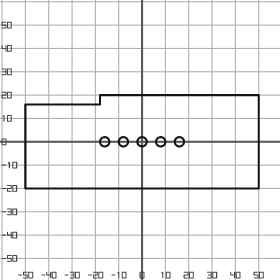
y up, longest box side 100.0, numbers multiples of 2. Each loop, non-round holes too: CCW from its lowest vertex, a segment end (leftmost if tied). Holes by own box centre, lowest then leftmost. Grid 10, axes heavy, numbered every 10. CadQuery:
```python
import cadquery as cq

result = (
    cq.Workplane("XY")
    .moveTo(-50.0, -20.0)
    .lineTo(50.0, -20.0)
    .lineTo(50.0, 20.0)
    .lineTo(-18.0, 20.0)
    .lineTo(-18.0, 16.0)
    .lineTo(-50.0, 16.0)
    .close()
    .moveTo(-16.0, 0.0)
    .circle(2.0)
    .moveTo(-8.0, 0.0)
    .circle(2.0)
    .moveTo(0.0, 0.0)
    .circle(2.0)
    .moveTo(8.0, 0.0)
    .circle(2.0)
    .moveTo(16.0, 0.0)
    .circle(2.0)
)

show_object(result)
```